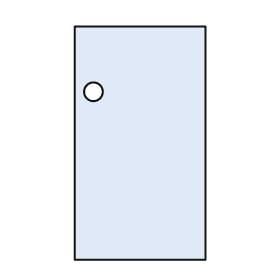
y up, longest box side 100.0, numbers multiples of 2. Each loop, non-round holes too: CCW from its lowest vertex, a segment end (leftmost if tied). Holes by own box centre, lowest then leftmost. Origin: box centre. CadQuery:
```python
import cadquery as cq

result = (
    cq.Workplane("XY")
    .moveTo(-28.0, -50.0)
    .lineTo(28.0, -50.0)
    .lineTo(28.0, 50.0)
    .lineTo(-28.0, 50.0)
    .close()
    .moveTo(-20.0, 22.0)
    .circle(4.0)
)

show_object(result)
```